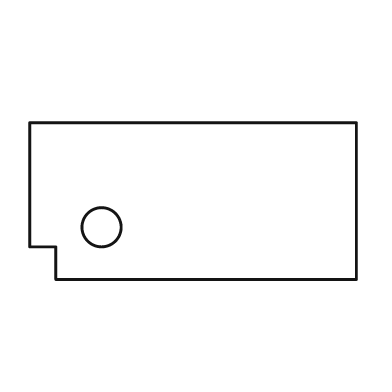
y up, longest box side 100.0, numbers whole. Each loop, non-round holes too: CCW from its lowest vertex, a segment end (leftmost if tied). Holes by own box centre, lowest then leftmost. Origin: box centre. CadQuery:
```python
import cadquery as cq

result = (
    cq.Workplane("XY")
    .moveTo(-42.0, -24.0)
    .lineTo(50.0, -24.0)
    .lineTo(50.0, 24.0)
    .lineTo(-50.0, 24.0)
    .lineTo(-50.0, -14.0)
    .lineTo(-42.0, -14.0)
    .close()
    .moveTo(-28.0, -8.0)
    .circle(6.0)
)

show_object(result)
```